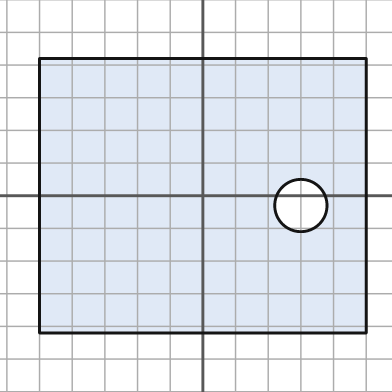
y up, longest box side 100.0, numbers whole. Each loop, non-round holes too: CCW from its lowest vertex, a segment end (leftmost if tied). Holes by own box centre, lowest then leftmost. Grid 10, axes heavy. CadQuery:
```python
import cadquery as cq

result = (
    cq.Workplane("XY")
    .moveTo(-50.0, -42.0)
    .lineTo(50.0, -42.0)
    .lineTo(50.0, 42.0)
    .lineTo(-50.0, 42.0)
    .close()
    .moveTo(30.0, -3.0)
    .circle(8.0)
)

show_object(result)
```